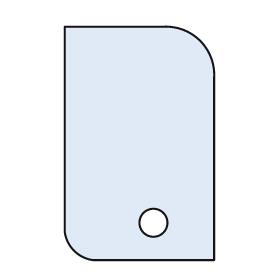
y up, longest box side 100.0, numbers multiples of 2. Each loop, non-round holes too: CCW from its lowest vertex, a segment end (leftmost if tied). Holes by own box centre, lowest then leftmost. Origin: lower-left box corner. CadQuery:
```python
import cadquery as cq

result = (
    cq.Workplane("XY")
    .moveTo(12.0, 0.0)
    .lineTo(64.0, 0.0)
    .lineTo(64.0, 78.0)
    .threePointArc((58.0, 94.0), (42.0, 100.0))
    .lineTo(0.0, 100.0)
    .lineTo(0.0, 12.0)
    .threePointArc((4.0, 4.0), (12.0, 0.0))
    .close()
    .moveTo(38.0, 16.0)
    .circle(6.0)
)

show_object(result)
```